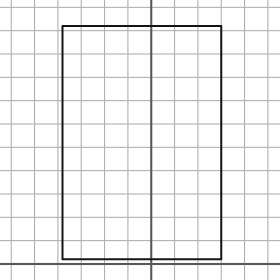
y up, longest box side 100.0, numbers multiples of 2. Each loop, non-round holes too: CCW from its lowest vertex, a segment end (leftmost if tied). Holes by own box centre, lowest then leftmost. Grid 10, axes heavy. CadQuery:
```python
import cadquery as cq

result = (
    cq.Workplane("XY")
    .moveTo(-38.0, 2.0)
    .lineTo(30.0, 2.0)
    .lineTo(30.0, 102.0)
    .lineTo(-38.0, 102.0)
    .close()
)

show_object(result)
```